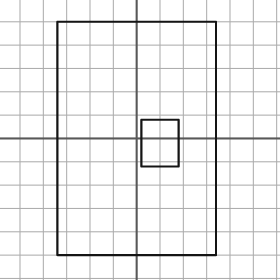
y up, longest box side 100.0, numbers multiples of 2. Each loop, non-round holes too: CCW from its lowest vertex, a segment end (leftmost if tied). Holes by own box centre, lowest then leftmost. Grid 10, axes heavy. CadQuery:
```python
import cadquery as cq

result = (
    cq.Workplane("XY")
    .moveTo(-34.0, -50.0)
    .lineTo(34.0, -50.0)
    .lineTo(34.0, 50.0)
    .lineTo(-34.0, 50.0)
    .close()
    .moveTo(2.0, -12.0)
    .lineTo(18.0, -12.0)
    .lineTo(18.0, 8.0)
    .lineTo(2.0, 8.0)
    .close()
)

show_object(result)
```